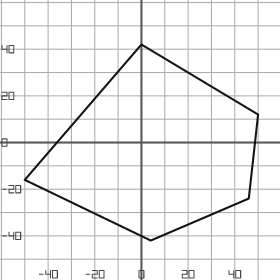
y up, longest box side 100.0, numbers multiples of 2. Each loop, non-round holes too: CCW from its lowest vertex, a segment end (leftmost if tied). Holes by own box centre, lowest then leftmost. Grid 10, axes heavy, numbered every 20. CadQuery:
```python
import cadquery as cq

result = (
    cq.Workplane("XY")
    .moveTo(4.0, -42.0)
    .lineTo(46.0, -24.0)
    .lineTo(50.0, 12.0)
    .lineTo(0.0, 42.0)
    .lineTo(-50.0, -16.0)
    .close()
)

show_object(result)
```